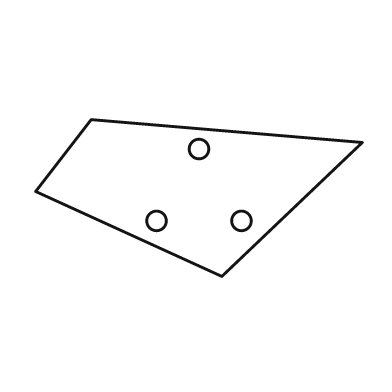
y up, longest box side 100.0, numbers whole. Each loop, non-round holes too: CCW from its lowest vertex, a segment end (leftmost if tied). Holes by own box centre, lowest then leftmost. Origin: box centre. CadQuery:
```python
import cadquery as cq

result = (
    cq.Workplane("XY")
    .moveTo(7.0, -24.0)
    .lineTo(50.0, 17.0)
    .lineTo(-33.0, 24.0)
    .lineTo(-50.0, 2.0)
    .close()
    .moveTo(-13.0, -7.0)
    .circle(3.0)
    .moveTo(13.0, -7.0)
    .circle(3.0)
    .moveTo(0.0, 15.0)
    .circle(3.0)
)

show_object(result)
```